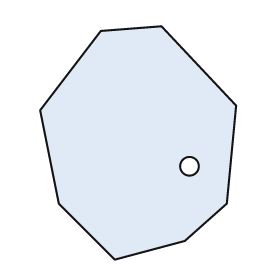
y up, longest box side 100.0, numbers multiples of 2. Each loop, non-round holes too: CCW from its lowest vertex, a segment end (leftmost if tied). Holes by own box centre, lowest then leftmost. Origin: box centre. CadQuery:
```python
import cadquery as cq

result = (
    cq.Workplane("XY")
    .moveTo(-10.0, -50.0)
    .lineTo(20.0, -42.0)
    .lineTo(38.0, -26.0)
    .lineTo(42.0, 16.0)
    .lineTo(10.0, 50.0)
    .lineTo(-16.0, 48.0)
    .lineTo(-42.0, 14.0)
    .lineTo(-34.0, -26.0)
    .close()
    .moveTo(22.0, -10.0)
    .circle(4.0)
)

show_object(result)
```